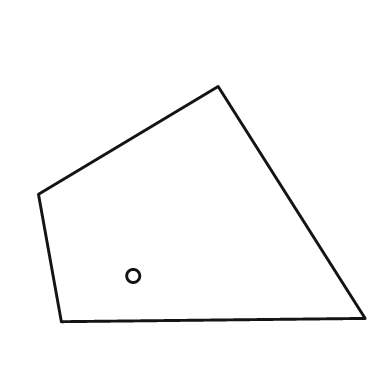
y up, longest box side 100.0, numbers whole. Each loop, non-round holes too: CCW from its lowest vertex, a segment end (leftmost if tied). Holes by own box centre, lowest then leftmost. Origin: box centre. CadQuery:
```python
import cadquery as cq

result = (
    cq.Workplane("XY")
    .moveTo(-43.0, -36.0)
    .lineTo(50.0, -35.0)
    .lineTo(5.0, 36.0)
    .lineTo(-50.0, 3.0)
    .close()
    .moveTo(-21.0, -22.0)
    .circle(2.0)
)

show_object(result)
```